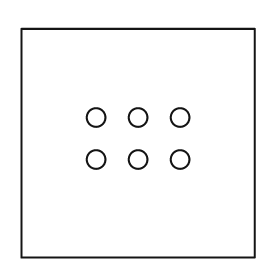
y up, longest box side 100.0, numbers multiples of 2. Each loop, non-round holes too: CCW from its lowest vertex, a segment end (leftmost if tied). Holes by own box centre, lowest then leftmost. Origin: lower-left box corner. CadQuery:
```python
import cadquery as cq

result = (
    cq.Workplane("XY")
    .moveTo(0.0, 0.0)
    .lineTo(100.0, 0.0)
    .lineTo(100.0, 98.0)
    .lineTo(0.0, 98.0)
    .close()
    .moveTo(32.0, 42.0)
    .circle(4.0)
    .moveTo(50.0, 42.0)
    .circle(4.0)
    .moveTo(68.0, 42.0)
    .circle(4.0)
    .moveTo(32.0, 60.0)
    .circle(4.0)
    .moveTo(50.0, 60.0)
    .circle(4.0)
    .moveTo(68.0, 60.0)
    .circle(4.0)
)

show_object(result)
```